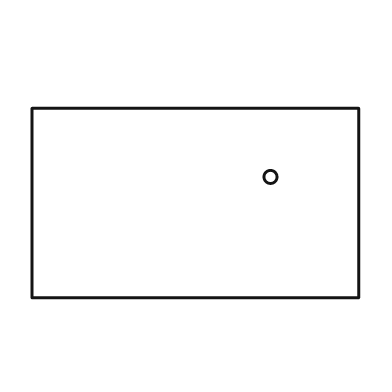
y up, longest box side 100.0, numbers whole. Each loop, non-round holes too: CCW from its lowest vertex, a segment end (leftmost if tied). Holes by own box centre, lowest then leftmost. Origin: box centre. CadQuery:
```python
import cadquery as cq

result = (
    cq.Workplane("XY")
    .moveTo(-50.0, -29.0)
    .lineTo(50.0, -29.0)
    .lineTo(50.0, 29.0)
    .lineTo(-50.0, 29.0)
    .close()
    .moveTo(23.0, 8.0)
    .circle(2.0)
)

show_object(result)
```